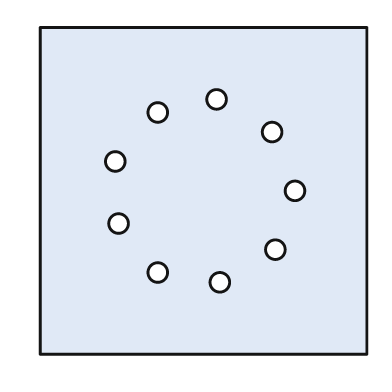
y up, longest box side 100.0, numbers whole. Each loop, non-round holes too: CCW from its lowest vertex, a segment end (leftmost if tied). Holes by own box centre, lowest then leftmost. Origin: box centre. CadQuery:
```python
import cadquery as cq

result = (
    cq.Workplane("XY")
    .moveTo(-50.0, -50.0)
    .lineTo(50.0, -50.0)
    .lineTo(50.0, 50.0)
    .lineTo(-50.0, 50.0)
    .close()
    .moveTo(5.0, -28.0)
    .circle(3.0)
    .moveTo(-14.0, -25.0)
    .circle(3.0)
    .moveTo(22.0, -18.0)
    .circle(3.0)
    .moveTo(-26.0, -10.0)
    .circle(3.0)
    .moveTo(28.0, 0.0)
    .circle(3.0)
    .moveTo(-27.0, 9.0)
    .circle(3.0)
    .moveTo(21.0, 18.0)
    .circle(3.0)
    .moveTo(-14.0, 24.0)
    .circle(3.0)
    .moveTo(4.0, 28.0)
    .circle(3.0)
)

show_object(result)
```